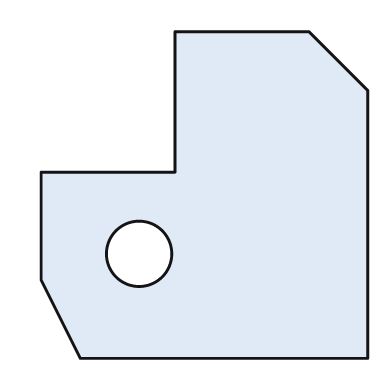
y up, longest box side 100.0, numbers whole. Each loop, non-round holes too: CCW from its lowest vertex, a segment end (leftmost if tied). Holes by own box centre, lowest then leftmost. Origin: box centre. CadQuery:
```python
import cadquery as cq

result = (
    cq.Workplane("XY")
    .moveTo(-38.0, -50.0)
    .lineTo(50.0, -50.0)
    .lineTo(50.0, 32.0)
    .lineTo(32.0, 50.0)
    .lineTo(-9.0, 50.0)
    .lineTo(-9.0, 7.0)
    .lineTo(-50.0, 7.0)
    .lineTo(-50.0, -26.0)
    .close()
    .moveTo(-20.0, -18.0)
    .circle(10.0)
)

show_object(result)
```